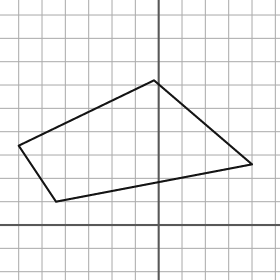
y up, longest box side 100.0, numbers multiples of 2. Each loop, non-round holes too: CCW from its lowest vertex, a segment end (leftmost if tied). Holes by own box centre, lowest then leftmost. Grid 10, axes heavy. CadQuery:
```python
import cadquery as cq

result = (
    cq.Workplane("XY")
    .moveTo(-44.0, 10.0)
    .lineTo(40.0, 26.0)
    .lineTo(-2.0, 62.0)
    .lineTo(-60.0, 34.0)
    .close()
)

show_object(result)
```